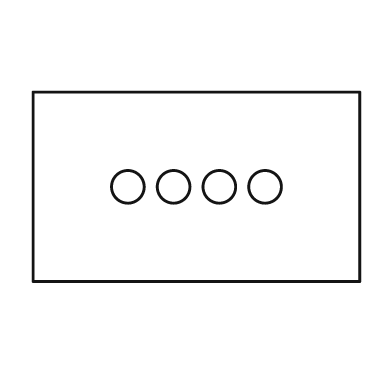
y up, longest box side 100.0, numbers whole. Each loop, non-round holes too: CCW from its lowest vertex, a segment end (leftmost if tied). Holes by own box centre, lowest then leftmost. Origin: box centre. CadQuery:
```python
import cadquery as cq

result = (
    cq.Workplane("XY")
    .moveTo(-50.0, -29.0)
    .lineTo(50.0, -29.0)
    .lineTo(50.0, 29.0)
    .lineTo(-50.0, 29.0)
    .close()
    .moveTo(-21.0, 0.0)
    .circle(5.0)
    .moveTo(-7.0, 0.0)
    .circle(5.0)
    .moveTo(7.0, 0.0)
    .circle(5.0)
    .moveTo(21.0, 0.0)
    .circle(5.0)
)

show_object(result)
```